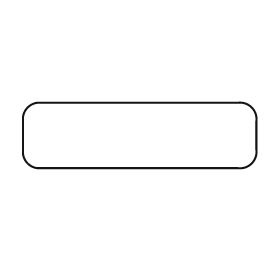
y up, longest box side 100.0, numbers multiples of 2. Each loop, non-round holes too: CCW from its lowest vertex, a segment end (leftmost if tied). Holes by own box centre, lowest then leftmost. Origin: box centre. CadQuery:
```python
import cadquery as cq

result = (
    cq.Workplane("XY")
    .moveTo(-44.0, -14.0)
    .lineTo(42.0, -14.0)
    .threePointArc((48.0, -12.0), (50.0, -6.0))
    .lineTo(50.0, 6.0)
    .threePointArc((48.0, 12.0), (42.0, 14.0))
    .lineTo(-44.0, 14.0)
    .threePointArc((-48.0, 12.0), (-50.0, 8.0))
    .lineTo(-50.0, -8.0)
    .threePointArc((-48.0, -12.0), (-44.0, -14.0))
    .close()
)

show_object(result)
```